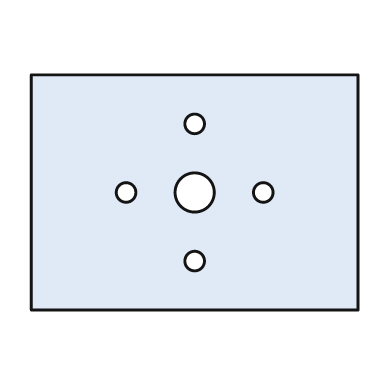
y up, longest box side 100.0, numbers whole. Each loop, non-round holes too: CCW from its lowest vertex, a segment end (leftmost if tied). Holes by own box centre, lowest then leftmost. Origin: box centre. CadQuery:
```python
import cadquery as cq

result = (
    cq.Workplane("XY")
    .moveTo(-50.0, -36.0)
    .lineTo(50.0, -36.0)
    .lineTo(50.0, 36.0)
    .lineTo(-50.0, 36.0)
    .close()
    .moveTo(0.0, -21.0)
    .circle(3.0)
    .moveTo(-21.0, 0.0)
    .circle(3.0)
    .moveTo(0.0, 0.0)
    .circle(6.0)
    .moveTo(21.0, 0.0)
    .circle(3.0)
    .moveTo(0.0, 21.0)
    .circle(3.0)
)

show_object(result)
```